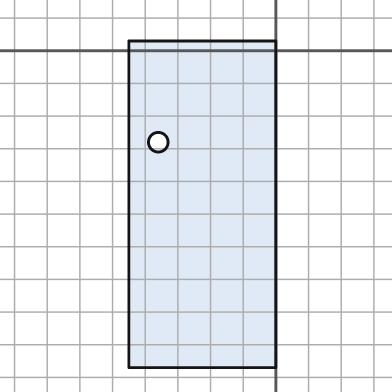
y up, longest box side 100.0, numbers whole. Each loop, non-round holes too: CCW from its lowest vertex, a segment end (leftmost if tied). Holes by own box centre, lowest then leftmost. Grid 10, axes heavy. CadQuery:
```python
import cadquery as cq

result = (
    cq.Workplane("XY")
    .moveTo(-45.0, -97.0)
    .lineTo(0.0, -97.0)
    .lineTo(0.0, 3.0)
    .lineTo(-45.0, 3.0)
    .close()
    .moveTo(-36.0, -28.0)
    .circle(3.0)
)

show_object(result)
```